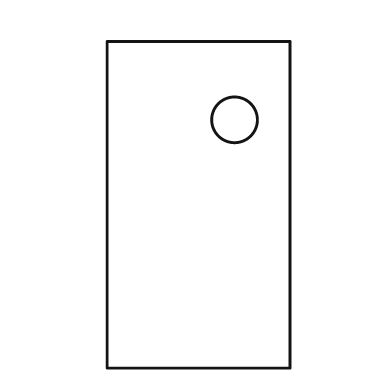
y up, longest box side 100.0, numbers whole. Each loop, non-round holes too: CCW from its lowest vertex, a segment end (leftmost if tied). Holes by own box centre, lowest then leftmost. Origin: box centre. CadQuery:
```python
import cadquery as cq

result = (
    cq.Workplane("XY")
    .moveTo(-28.0, -50.0)
    .lineTo(28.0, -50.0)
    .lineTo(28.0, 50.0)
    .lineTo(-28.0, 50.0)
    .close()
    .moveTo(11.0, 26.0)
    .circle(7.0)
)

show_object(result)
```